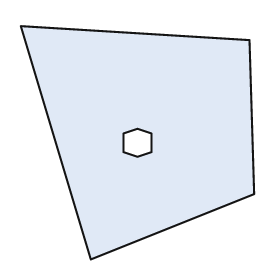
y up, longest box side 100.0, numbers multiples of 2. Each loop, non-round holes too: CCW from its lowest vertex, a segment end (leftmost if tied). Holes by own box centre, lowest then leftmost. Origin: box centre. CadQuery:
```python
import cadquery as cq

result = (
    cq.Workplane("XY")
    .moveTo(-20.0, -50.0)
    .lineTo(50.0, -22.0)
    .lineTo(48.0, 44.0)
    .lineTo(-50.0, 50.0)
    .close()
    .moveTo(0.0, -6.0)
    .lineTo(6.0, -4.0)
    .lineTo(6.0, 4.0)
    .lineTo(0.0, 6.0)
    .lineTo(-6.0, 4.0)
    .lineTo(-6.0, -4.0)
    .close()
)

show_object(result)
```